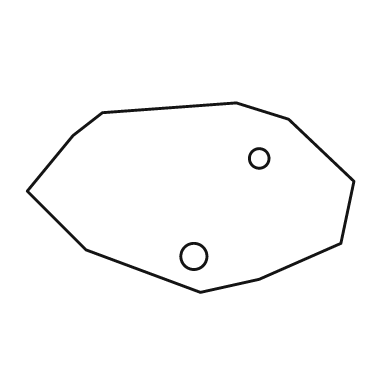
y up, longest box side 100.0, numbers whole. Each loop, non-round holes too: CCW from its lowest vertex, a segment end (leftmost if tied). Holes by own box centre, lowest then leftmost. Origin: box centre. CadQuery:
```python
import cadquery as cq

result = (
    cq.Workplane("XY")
    .moveTo(3.0, -29.0)
    .lineTo(21.0, -25.0)
    .lineTo(46.0, -14.0)
    .lineTo(50.0, 5.0)
    .lineTo(30.0, 24.0)
    .lineTo(14.0, 29.0)
    .lineTo(-27.0, 26.0)
    .lineTo(-36.0, 19.0)
    .lineTo(-50.0, 2.0)
    .lineTo(-32.0, -16.0)
    .close()
    .moveTo(1.0, -18.0)
    .circle(4.0)
    .moveTo(21.0, 12.0)
    .circle(3.0)
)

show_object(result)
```